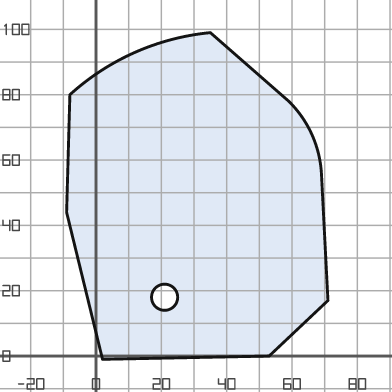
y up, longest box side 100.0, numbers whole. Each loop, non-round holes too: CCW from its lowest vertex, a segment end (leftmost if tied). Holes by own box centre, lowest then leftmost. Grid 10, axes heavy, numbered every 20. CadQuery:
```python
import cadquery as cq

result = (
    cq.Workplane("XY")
    .moveTo(2.0, -1.0)
    .lineTo(53.0, 0.0)
    .lineTo(71.0, 17.0)
    .lineTo(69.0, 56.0)
    .threePointArc((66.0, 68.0), (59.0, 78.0))
    .lineTo(35.0, 99.0)
    .threePointArc((12.0, 93.0), (-8.0, 80.0))
    .lineTo(-9.0, 44.0)
    .close()
    .moveTo(21.0, 18.0)
    .circle(4.0)
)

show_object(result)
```